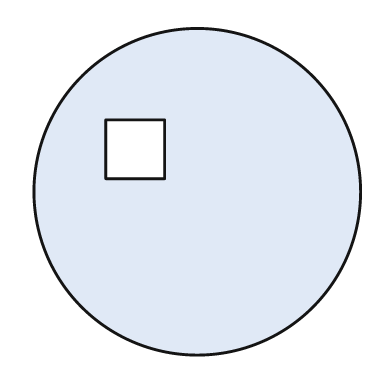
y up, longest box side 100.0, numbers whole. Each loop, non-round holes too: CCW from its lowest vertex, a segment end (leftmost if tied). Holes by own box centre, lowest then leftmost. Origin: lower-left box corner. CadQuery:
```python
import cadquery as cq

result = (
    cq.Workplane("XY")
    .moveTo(50.0, 50.0)
    .circle(50.0)
    .moveTo(22.0, 54.0)
    .lineTo(40.0, 54.0)
    .lineTo(40.0, 72.0)
    .lineTo(22.0, 72.0)
    .close()
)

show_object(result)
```